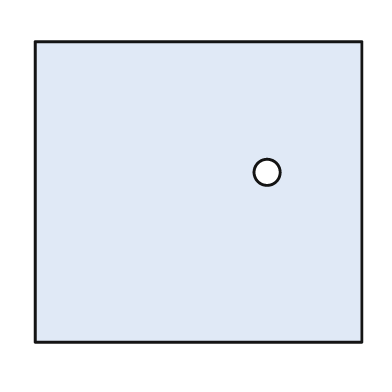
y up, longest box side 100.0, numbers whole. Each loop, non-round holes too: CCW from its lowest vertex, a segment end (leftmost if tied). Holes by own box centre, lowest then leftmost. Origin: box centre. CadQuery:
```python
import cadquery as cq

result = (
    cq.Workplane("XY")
    .moveTo(-50.0, -46.0)
    .lineTo(50.0, -46.0)
    .lineTo(50.0, 46.0)
    .lineTo(-50.0, 46.0)
    .close()
    .moveTo(21.0, 6.0)
    .circle(4.0)
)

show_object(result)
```